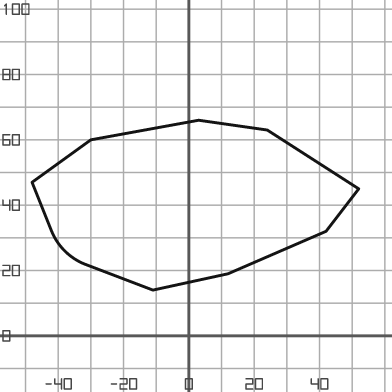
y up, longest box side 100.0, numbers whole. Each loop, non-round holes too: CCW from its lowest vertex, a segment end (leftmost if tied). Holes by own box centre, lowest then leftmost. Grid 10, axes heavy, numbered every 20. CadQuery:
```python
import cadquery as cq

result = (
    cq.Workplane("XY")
    .moveTo(-11.0, 14.0)
    .lineTo(12.0, 19.0)
    .lineTo(42.0, 32.0)
    .lineTo(52.0, 45.0)
    .lineTo(24.0, 63.0)
    .lineTo(3.0, 66.0)
    .lineTo(-30.0, 60.0)
    .lineTo(-48.0, 47.0)
    .lineTo(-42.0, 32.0)
    .threePointArc((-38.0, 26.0), (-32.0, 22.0))
    .close()
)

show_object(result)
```